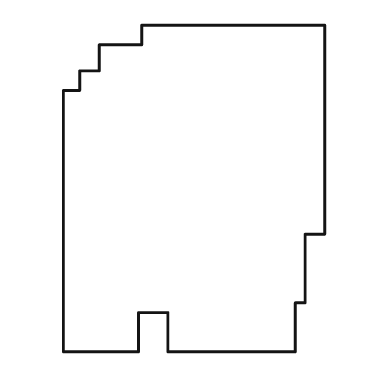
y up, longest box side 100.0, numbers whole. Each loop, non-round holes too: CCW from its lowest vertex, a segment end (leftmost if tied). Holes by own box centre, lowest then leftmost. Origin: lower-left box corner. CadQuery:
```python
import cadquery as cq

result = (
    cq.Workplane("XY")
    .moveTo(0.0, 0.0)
    .lineTo(23.0, 0.0)
    .lineTo(23.0, 12.0)
    .lineTo(32.0, 12.0)
    .lineTo(32.0, 0.0)
    .lineTo(71.0, 0.0)
    .lineTo(71.0, 15.0)
    .lineTo(74.0, 15.0)
    .lineTo(74.0, 36.0)
    .lineTo(80.0, 36.0)
    .lineTo(80.0, 100.0)
    .lineTo(24.0, 100.0)
    .lineTo(24.0, 94.0)
    .lineTo(11.0, 94.0)
    .lineTo(11.0, 86.0)
    .lineTo(5.0, 86.0)
    .lineTo(5.0, 80.0)
    .lineTo(0.0, 80.0)
    .close()
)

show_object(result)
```